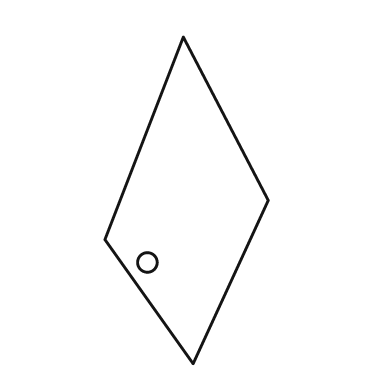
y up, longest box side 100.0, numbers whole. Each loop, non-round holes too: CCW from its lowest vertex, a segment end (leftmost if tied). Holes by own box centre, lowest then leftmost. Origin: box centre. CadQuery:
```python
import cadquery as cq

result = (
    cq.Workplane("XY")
    .moveTo(2.0, -50.0)
    .lineTo(25.0, 0.0)
    .lineTo(-1.0, 50.0)
    .lineTo(-25.0, -12.0)
    .close()
    .moveTo(-12.0, -19.0)
    .circle(3.0)
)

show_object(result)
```